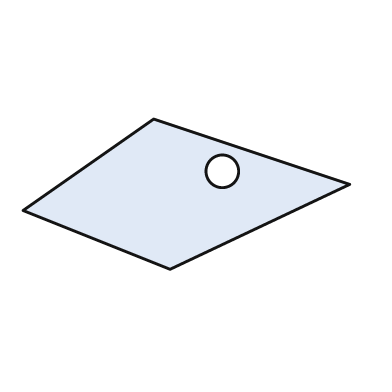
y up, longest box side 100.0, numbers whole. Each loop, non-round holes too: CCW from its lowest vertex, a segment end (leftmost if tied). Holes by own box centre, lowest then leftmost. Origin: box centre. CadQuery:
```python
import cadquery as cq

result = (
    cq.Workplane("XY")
    .moveTo(-5.0, -23.0)
    .lineTo(50.0, 3.0)
    .lineTo(-10.0, 23.0)
    .lineTo(-50.0, -5.0)
    .close()
    .moveTo(11.0, 7.0)
    .circle(5.0)
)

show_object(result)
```